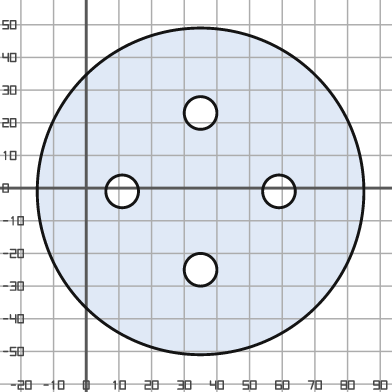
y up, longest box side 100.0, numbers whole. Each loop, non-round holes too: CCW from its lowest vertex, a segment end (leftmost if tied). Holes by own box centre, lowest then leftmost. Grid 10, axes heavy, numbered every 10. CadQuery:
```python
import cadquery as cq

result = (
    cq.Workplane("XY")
    .moveTo(35.0, -1.0)
    .circle(50.0)
    .moveTo(35.0, -25.0)
    .circle(5.0)
    .moveTo(11.0, -1.0)
    .circle(5.0)
    .moveTo(59.0, -1.0)
    .circle(5.0)
    .moveTo(35.0, 23.0)
    .circle(5.0)
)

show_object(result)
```